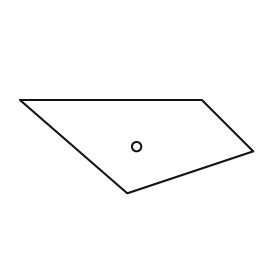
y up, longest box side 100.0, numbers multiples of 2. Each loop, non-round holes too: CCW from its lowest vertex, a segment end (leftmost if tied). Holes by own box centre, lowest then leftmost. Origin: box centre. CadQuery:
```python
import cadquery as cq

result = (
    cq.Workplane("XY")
    .moveTo(-4.0, -20.0)
    .lineTo(50.0, -2.0)
    .lineTo(28.0, 20.0)
    .lineTo(-50.0, 20.0)
    .close()
    .moveTo(0.0, 0.0)
    .circle(2.0)
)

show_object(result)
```